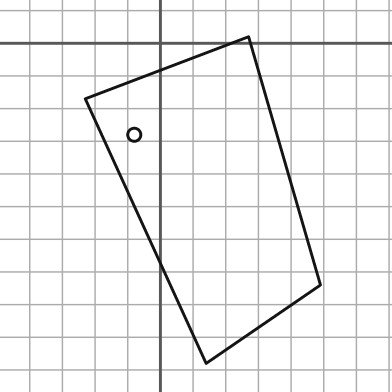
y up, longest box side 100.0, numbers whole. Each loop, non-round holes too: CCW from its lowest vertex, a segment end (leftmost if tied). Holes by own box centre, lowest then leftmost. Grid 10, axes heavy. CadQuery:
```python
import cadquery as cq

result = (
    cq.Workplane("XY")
    .moveTo(14.0, -98.0)
    .lineTo(49.0, -74.0)
    .lineTo(27.0, 2.0)
    .lineTo(-23.0, -17.0)
    .close()
    .moveTo(-8.0, -28.0)
    .circle(2.0)
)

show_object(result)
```